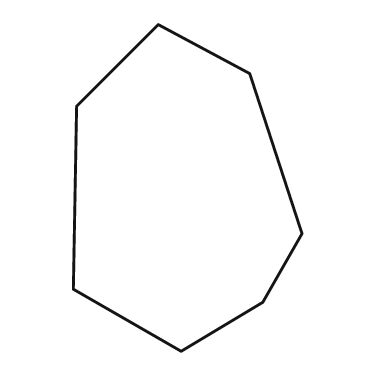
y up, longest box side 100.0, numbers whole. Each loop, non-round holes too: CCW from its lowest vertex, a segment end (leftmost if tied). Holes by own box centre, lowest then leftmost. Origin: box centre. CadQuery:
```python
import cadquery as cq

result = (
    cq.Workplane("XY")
    .moveTo(-2.0, -50.0)
    .lineTo(23.0, -35.0)
    .lineTo(35.0, -14.0)
    .lineTo(19.0, 35.0)
    .lineTo(-9.0, 50.0)
    .lineTo(-34.0, 25.0)
    .lineTo(-35.0, -31.0)
    .close()
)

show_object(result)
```